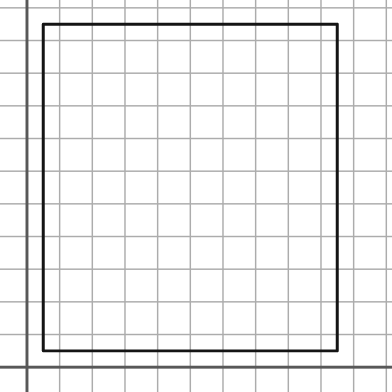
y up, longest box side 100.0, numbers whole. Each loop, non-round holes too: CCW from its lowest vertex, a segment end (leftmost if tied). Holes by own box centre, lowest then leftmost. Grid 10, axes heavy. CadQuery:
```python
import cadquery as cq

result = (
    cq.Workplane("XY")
    .moveTo(5.0, 5.0)
    .lineTo(95.0, 5.0)
    .lineTo(95.0, 105.0)
    .lineTo(5.0, 105.0)
    .close()
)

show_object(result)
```